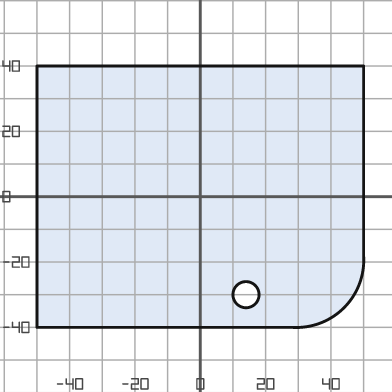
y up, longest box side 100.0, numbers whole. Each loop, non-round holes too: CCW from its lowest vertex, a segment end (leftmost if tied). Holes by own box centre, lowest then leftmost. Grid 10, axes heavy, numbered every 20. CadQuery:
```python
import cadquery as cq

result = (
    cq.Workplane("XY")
    .moveTo(-50.0, -40.0)
    .lineTo(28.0, -40.0)
    .threePointArc((44.0, -34.0), (50.0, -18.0))
    .lineTo(50.0, 40.0)
    .lineTo(-50.0, 40.0)
    .close()
    .moveTo(14.0, -30.0)
    .circle(4.0)
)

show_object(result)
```